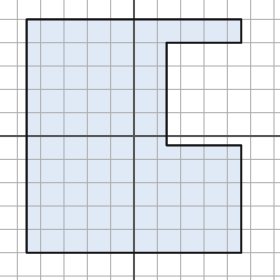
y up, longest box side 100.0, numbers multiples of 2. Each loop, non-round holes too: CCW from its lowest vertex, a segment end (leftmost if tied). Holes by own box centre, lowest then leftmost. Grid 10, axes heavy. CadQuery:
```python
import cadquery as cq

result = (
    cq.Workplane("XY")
    .moveTo(-46.0, -50.0)
    .lineTo(46.0, -50.0)
    .lineTo(46.0, -4.0)
    .lineTo(14.0, -4.0)
    .lineTo(14.0, 40.0)
    .lineTo(46.0, 40.0)
    .lineTo(46.0, 50.0)
    .lineTo(-46.0, 50.0)
    .close()
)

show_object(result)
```